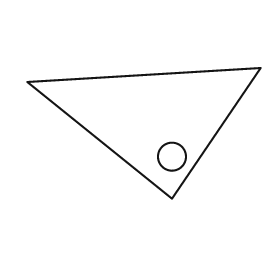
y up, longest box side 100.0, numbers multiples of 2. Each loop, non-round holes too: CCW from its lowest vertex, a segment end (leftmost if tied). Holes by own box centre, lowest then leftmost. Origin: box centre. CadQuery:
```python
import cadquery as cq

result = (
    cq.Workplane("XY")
    .moveTo(12.0, -28.0)
    .lineTo(50.0, 28.0)
    .lineTo(-50.0, 22.0)
    .close()
    .moveTo(12.0, -10.0)
    .circle(6.0)
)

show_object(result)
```